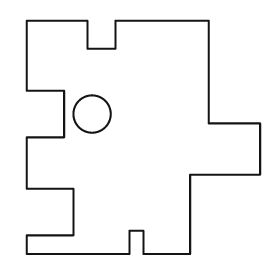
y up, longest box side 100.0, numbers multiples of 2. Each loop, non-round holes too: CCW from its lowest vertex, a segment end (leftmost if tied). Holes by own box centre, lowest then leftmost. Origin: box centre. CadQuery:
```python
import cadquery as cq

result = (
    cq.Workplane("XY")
    .moveTo(-50.0, -50.0)
    .lineTo(-6.0, -50.0)
    .lineTo(-6.0, -40.0)
    .lineTo(0.0, -40.0)
    .lineTo(0.0, -50.0)
    .lineTo(20.0, -50.0)
    .lineTo(20.0, -16.0)
    .lineTo(50.0, -16.0)
    .lineTo(50.0, 6.0)
    .lineTo(28.0, 6.0)
    .lineTo(28.0, 50.0)
    .lineTo(-12.0, 50.0)
    .lineTo(-12.0, 38.0)
    .lineTo(-24.0, 38.0)
    .lineTo(-24.0, 50.0)
    .lineTo(-50.0, 50.0)
    .lineTo(-50.0, 20.0)
    .lineTo(-34.0, 20.0)
    .lineTo(-34.0, 0.0)
    .lineTo(-50.0, 0.0)
    .lineTo(-50.0, -22.0)
    .lineTo(-30.0, -22.0)
    .lineTo(-30.0, -42.0)
    .lineTo(-50.0, -42.0)
    .close()
    .moveTo(-22.0, 10.0)
    .circle(8.0)
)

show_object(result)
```